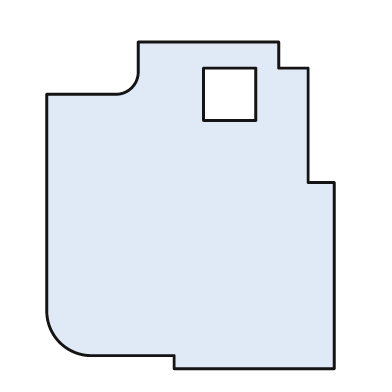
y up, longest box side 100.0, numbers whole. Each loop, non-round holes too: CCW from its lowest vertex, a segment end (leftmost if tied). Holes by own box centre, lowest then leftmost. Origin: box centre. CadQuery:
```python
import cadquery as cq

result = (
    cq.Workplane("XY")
    .moveTo(-5.0, -50.0)
    .lineTo(44.0, -50.0)
    .lineTo(44.0, 7.0)
    .lineTo(36.0, 7.0)
    .lineTo(36.0, 42.0)
    .lineTo(27.0, 42.0)
    .lineTo(27.0, 50.0)
    .lineTo(-16.0, 50.0)
    .lineTo(-16.0, 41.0)
    .threePointArc((-18.0, 36.0), (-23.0, 34.0))
    .lineTo(-44.0, 34.0)
    .lineTo(-44.0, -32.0)
    .threePointArc((-40.0, -42.0), (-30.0, -46.0))
    .lineTo(-5.0, -46.0)
    .close()
    .moveTo(4.0, 26.0)
    .lineTo(20.0, 26.0)
    .lineTo(20.0, 42.0)
    .lineTo(4.0, 42.0)
    .close()
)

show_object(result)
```